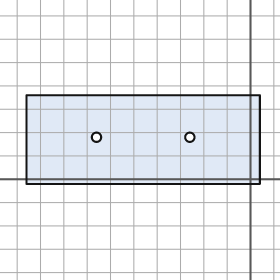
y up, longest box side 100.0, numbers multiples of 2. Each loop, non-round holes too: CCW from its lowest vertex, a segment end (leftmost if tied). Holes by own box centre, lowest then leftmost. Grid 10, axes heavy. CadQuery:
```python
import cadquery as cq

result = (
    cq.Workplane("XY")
    .moveTo(-96.0, -2.0)
    .lineTo(4.0, -2.0)
    .lineTo(4.0, 36.0)
    .lineTo(-96.0, 36.0)
    .close()
    .moveTo(-66.0, 18.0)
    .circle(2.0)
    .moveTo(-26.0, 18.0)
    .circle(2.0)
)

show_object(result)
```